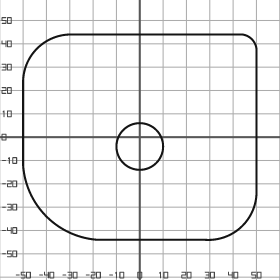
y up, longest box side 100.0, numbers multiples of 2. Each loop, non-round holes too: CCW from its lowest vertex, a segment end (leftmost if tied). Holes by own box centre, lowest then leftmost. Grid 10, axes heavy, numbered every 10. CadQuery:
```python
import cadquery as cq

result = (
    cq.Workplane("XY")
    .moveTo(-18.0, -44.0)
    .lineTo(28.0, -44.0)
    .threePointArc((44.0, -38.0), (50.0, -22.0))
    .lineTo(50.0, 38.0)
    .threePointArc((48.0, 42.0), (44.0, 44.0))
    .lineTo(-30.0, 44.0)
    .threePointArc((-44.0, 38.0), (-50.0, 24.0))
    .lineTo(-50.0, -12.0)
    .threePointArc((-40.0, -34.0), (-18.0, -44.0))
    .close()
    .moveTo(0.0, -4.0)
    .circle(10.0)
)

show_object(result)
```